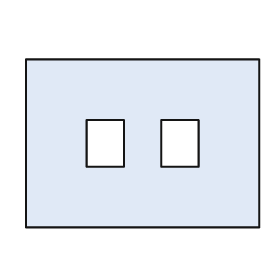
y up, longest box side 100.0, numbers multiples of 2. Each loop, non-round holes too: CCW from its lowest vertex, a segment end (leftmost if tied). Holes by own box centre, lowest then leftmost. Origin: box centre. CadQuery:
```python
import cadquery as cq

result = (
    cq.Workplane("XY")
    .moveTo(-50.0, -36.0)
    .lineTo(50.0, -36.0)
    .lineTo(50.0, 36.0)
    .lineTo(-50.0, 36.0)
    .close()
    .moveTo(-24.0, -10.0)
    .lineTo(-8.0, -10.0)
    .lineTo(-8.0, 10.0)
    .lineTo(-24.0, 10.0)
    .close()
    .moveTo(8.0, -10.0)
    .lineTo(24.0, -10.0)
    .lineTo(24.0, 10.0)
    .lineTo(8.0, 10.0)
    .close()
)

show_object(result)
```